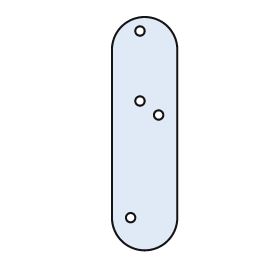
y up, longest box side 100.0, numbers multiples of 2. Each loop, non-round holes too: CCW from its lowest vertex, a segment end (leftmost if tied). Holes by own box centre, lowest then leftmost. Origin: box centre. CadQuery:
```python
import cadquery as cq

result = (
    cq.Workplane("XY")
    .moveTo(-14.0, -36.0)
    .threePointArc((0.0, -50.0), (14.0, -36.0))
    .lineTo(14.0, 36.0)
    .threePointArc((0.0, 50.0), (-14.0, 36.0))
    .close()
    .moveTo(-6.0, -36.0)
    .circle(2.0)
    .moveTo(6.0, 8.0)
    .circle(2.0)
    .moveTo(-2.0, 14.0)
    .circle(2.0)
    .moveTo(-2.0, 44.0)
    .circle(2.0)
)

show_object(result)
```